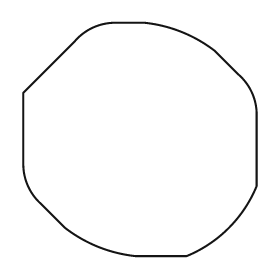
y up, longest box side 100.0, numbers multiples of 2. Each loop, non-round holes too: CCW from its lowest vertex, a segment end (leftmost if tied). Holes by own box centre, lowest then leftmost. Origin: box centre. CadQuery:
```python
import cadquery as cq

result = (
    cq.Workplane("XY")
    .moveTo(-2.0, -50.0)
    .lineTo(20.0, -50.0)
    .threePointArc((38.0, -38.0), (50.0, -20.0))
    .lineTo(50.0, 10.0)
    .threePointArc((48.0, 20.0), (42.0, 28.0))
    .lineTo(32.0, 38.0)
    .threePointArc((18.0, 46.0), (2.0, 50.0))
    .lineTo(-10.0, 50.0)
    .threePointArc((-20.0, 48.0), (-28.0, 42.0))
    .lineTo(-50.0, 20.0)
    .lineTo(-50.0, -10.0)
    .threePointArc((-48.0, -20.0), (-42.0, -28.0))
    .lineTo(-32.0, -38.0)
    .threePointArc((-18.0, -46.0), (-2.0, -50.0))
    .close()
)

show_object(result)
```